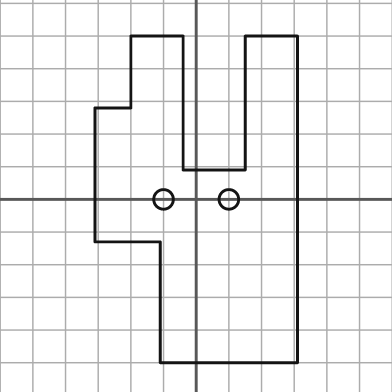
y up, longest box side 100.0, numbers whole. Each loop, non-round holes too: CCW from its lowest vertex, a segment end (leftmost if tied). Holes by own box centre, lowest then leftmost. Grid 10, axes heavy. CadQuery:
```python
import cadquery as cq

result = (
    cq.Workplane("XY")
    .moveTo(-11.0, -50.0)
    .lineTo(31.0, -50.0)
    .lineTo(31.0, 50.0)
    .lineTo(15.0, 50.0)
    .lineTo(15.0, 9.0)
    .lineTo(-4.0, 9.0)
    .lineTo(-4.0, 50.0)
    .lineTo(-20.0, 50.0)
    .lineTo(-20.0, 28.0)
    .lineTo(-31.0, 28.0)
    .lineTo(-31.0, -13.0)
    .lineTo(-11.0, -13.0)
    .close()
    .moveTo(-10.0, 0.0)
    .circle(3.0)
    .moveTo(10.0, 0.0)
    .circle(3.0)
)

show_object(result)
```